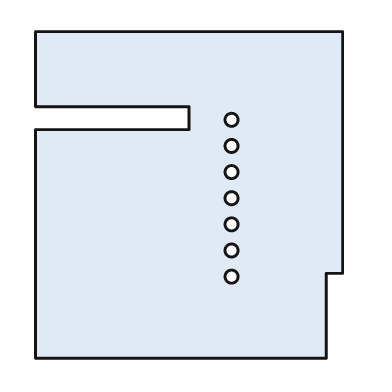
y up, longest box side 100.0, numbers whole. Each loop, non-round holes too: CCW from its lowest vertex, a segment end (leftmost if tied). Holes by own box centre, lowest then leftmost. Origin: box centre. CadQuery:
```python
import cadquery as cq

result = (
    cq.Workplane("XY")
    .moveTo(-47.0, -50.0)
    .lineTo(42.0, -50.0)
    .lineTo(42.0, -24.0)
    .lineTo(47.0, -24.0)
    .lineTo(47.0, 50.0)
    .lineTo(-47.0, 50.0)
    .lineTo(-47.0, 27.0)
    .lineTo(0.0, 27.0)
    .lineTo(0.0, 20.0)
    .lineTo(-47.0, 20.0)
    .close()
    .moveTo(13.0, -25.0)
    .circle(2.0)
    .moveTo(13.0, -17.0)
    .circle(2.0)
    .moveTo(13.0, -9.0)
    .circle(2.0)
    .moveTo(13.0, -1.0)
    .circle(2.0)
    .moveTo(13.0, 7.0)
    .circle(2.0)
    .moveTo(13.0, 15.0)
    .circle(2.0)
    .moveTo(13.0, 23.0)
    .circle(2.0)
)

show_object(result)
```